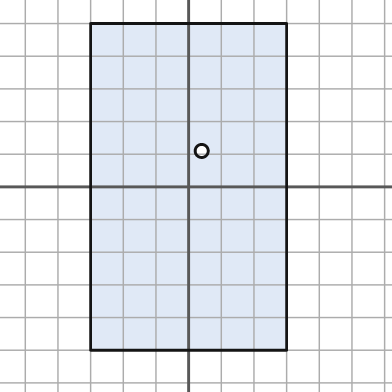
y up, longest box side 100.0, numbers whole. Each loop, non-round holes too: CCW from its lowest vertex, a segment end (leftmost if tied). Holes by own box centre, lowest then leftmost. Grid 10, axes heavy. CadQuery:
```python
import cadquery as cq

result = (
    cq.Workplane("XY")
    .moveTo(-30.0, -50.0)
    .lineTo(30.0, -50.0)
    .lineTo(30.0, 50.0)
    .lineTo(-30.0, 50.0)
    .close()
    .moveTo(4.0, 11.0)
    .circle(2.0)
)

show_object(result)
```